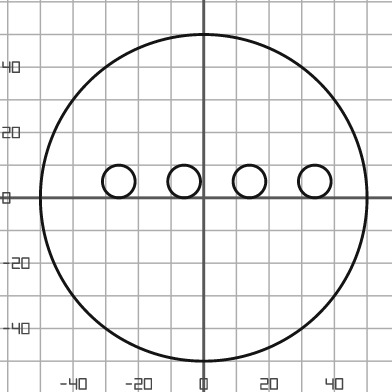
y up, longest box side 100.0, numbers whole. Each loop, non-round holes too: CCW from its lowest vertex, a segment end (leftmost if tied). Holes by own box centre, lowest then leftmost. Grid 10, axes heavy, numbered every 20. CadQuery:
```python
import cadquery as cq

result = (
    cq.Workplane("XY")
    .moveTo(0.0, 0.0)
    .circle(50.0)
    .moveTo(-26.0, 5.0)
    .circle(5.0)
    .moveTo(-6.0, 5.0)
    .circle(5.0)
    .moveTo(14.0, 5.0)
    .circle(5.0)
    .moveTo(34.0, 5.0)
    .circle(5.0)
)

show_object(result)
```